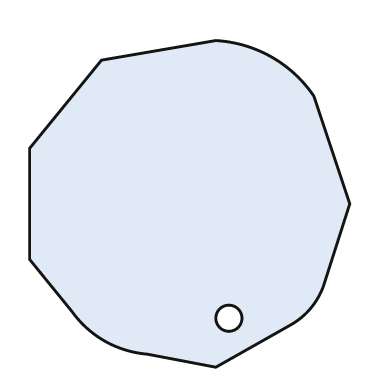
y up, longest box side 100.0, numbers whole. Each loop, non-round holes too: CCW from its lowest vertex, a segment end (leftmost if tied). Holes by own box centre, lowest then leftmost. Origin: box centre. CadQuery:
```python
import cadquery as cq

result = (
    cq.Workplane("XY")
    .moveTo(8.0, -50.0)
    .lineTo(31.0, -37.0)
    .threePointArc((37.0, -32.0), (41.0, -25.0))
    .lineTo(49.0, 0.0)
    .lineTo(38.0, 33.0)
    .threePointArc((25.0, 45.0), (8.0, 50.0))
    .lineTo(-27.0, 44.0)
    .lineTo(-49.0, 17.0)
    .lineTo(-49.0, -17.0)
    .lineTo(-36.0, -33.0)
    .threePointArc((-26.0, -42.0), (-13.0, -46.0))
    .close()
    .moveTo(12.0, -35.0)
    .circle(4.0)
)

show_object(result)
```